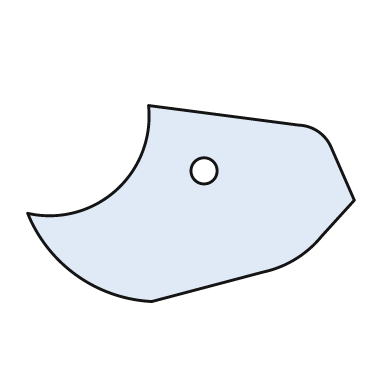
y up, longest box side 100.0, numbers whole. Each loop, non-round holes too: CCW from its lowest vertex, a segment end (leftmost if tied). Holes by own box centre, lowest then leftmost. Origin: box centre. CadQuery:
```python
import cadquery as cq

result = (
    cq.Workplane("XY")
    .moveTo(-12.0, -30.0)
    .lineTo(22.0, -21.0)
    .threePointArc((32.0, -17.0), (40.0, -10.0))
    .lineTo(50.0, 1.0)
    .lineTo(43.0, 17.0)
    .threePointArc((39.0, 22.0), (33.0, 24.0))
    .lineTo(-13.0, 30.0)
    .threePointArc((-23.0, 4.0), (-50.0, -3.0))
    .threePointArc((-35.0, -22.0), (-12.0, -30.0))
    .close()
    .moveTo(4.0, 10.0)
    .circle(4.0)
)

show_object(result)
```